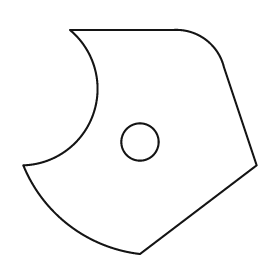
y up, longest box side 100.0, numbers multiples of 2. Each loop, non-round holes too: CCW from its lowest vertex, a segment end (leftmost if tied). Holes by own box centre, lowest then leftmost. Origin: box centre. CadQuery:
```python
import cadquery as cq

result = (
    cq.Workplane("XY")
    .moveTo(0.0, -48.0)
    .lineTo(50.0, -10.0)
    .lineTo(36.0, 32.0)
    .threePointArc((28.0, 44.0), (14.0, 48.0))
    .lineTo(-30.0, 48.0)
    .threePointArc((-20.0, 12.0), (-50.0, -10.0))
    .threePointArc((-30.0, -36.0), (0.0, -48.0))
    .close()
    .moveTo(0.0, 0.0)
    .circle(8.0)
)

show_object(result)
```